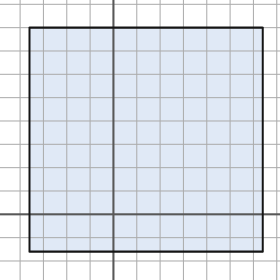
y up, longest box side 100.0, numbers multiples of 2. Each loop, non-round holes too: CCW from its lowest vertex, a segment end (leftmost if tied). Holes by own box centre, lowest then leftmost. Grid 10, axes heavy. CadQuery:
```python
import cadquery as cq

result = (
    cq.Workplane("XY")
    .moveTo(-36.0, -16.0)
    .lineTo(64.0, -16.0)
    .lineTo(64.0, 80.0)
    .lineTo(-36.0, 80.0)
    .close()
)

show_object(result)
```